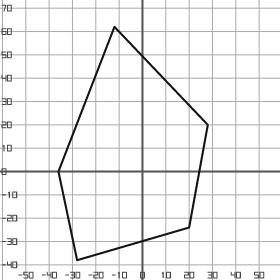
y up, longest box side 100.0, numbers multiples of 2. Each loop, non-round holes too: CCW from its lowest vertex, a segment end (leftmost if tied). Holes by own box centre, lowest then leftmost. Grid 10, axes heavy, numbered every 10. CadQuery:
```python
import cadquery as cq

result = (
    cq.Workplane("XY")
    .moveTo(-28.0, -38.0)
    .lineTo(20.0, -24.0)
    .lineTo(28.0, 20.0)
    .lineTo(-12.0, 62.0)
    .lineTo(-36.0, 0.0)
    .close()
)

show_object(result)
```